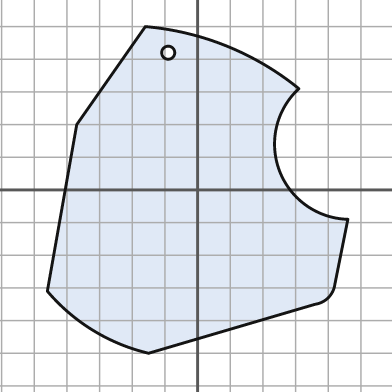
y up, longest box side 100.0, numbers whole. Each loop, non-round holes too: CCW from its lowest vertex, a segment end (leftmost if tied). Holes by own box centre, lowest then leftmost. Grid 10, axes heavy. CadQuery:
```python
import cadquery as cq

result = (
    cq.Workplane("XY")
    .moveTo(-15.0, -50.0)
    .lineTo(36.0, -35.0)
    .threePointArc((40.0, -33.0), (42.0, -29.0))
    .lineTo(46.0, -9.0)
    .threePointArc((25.0, 6.0), (31.0, 31.0))
    .threePointArc((9.0, 44.0), (-16.0, 50.0))
    .lineTo(-37.0, 20.0)
    .lineTo(-46.0, -31.0)
    .threePointArc((-32.0, -43.0), (-15.0, -50.0))
    .close()
    .moveTo(-9.0, 42.0)
    .circle(2.0)
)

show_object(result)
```